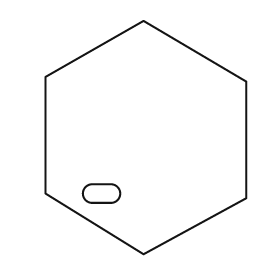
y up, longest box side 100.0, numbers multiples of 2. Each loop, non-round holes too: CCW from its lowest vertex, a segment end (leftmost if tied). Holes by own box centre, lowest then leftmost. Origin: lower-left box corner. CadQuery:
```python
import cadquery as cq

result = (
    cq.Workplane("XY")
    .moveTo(42.0, 0.0)
    .lineTo(86.0, 24.0)
    .lineTo(86.0, 74.0)
    .lineTo(42.0, 100.0)
    .lineTo(0.0, 76.0)
    .lineTo(0.0, 26.0)
    .close()
    .moveTo(20.0, 22.0)
    .lineTo(28.0, 22.0)
    .threePointArc((32.0, 26.0), (28.0, 30.0))
    .lineTo(20.0, 30.0)
    .threePointArc((16.0, 26.0), (20.0, 22.0))
    .close()
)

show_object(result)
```